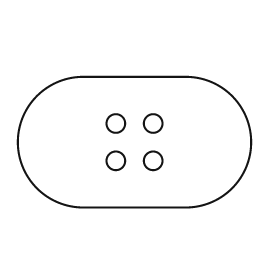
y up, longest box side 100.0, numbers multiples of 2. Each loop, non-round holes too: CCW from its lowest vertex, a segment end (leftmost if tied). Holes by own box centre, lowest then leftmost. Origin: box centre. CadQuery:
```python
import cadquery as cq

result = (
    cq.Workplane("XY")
    .moveTo(-22.0, -28.0)
    .lineTo(22.0, -28.0)
    .threePointArc((50.0, 0.0), (22.0, 28.0))
    .lineTo(-22.0, 28.0)
    .threePointArc((-50.0, 0.0), (-22.0, -28.0))
    .close()
    .moveTo(-8.0, -8.0)
    .circle(4.0)
    .moveTo(8.0, -8.0)
    .circle(4.0)
    .moveTo(-8.0, 8.0)
    .circle(4.0)
    .moveTo(8.0, 8.0)
    .circle(4.0)
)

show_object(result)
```